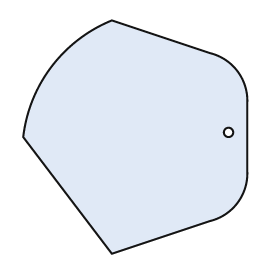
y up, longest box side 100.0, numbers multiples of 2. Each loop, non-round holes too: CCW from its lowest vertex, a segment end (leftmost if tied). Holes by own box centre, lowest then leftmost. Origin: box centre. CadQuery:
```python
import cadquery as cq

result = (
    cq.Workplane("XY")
    .moveTo(-10.0, -50.0)
    .lineTo(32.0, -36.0)
    .threePointArc((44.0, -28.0), (48.0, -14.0))
    .lineTo(48.0, 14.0)
    .threePointArc((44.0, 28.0), (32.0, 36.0))
    .lineTo(-10.0, 50.0)
    .threePointArc((-36.0, 30.0), (-48.0, 0.0))
    .close()
    .moveTo(40.0, 2.0)
    .circle(2.0)
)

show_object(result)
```